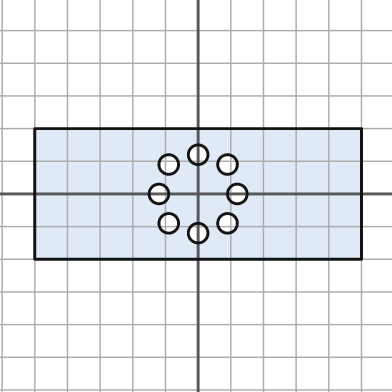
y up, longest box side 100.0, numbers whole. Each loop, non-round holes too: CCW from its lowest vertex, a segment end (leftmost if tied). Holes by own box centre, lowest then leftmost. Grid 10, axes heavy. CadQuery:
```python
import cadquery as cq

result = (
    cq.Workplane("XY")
    .moveTo(-50.0, -20.0)
    .lineTo(50.0, -20.0)
    .lineTo(50.0, 20.0)
    .lineTo(-50.0, 20.0)
    .close()
    .moveTo(0.0, -12.0)
    .circle(3.0)
    .moveTo(-9.0, -9.0)
    .circle(3.0)
    .moveTo(9.0, -9.0)
    .circle(3.0)
    .moveTo(-12.0, 0.0)
    .circle(3.0)
    .moveTo(12.0, 0.0)
    .circle(3.0)
    .moveTo(-9.0, 9.0)
    .circle(3.0)
    .moveTo(9.0, 9.0)
    .circle(3.0)
    .moveTo(0.0, 12.0)
    .circle(3.0)
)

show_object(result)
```